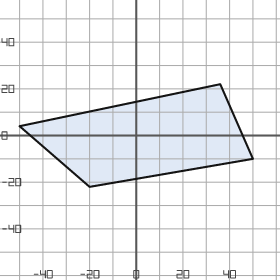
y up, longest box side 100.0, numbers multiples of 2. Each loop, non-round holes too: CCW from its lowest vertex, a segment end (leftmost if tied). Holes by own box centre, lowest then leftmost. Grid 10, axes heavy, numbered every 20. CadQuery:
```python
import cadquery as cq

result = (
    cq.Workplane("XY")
    .moveTo(-20.0, -22.0)
    .lineTo(50.0, -10.0)
    .lineTo(36.0, 22.0)
    .lineTo(-50.0, 4.0)
    .close()
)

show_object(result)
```